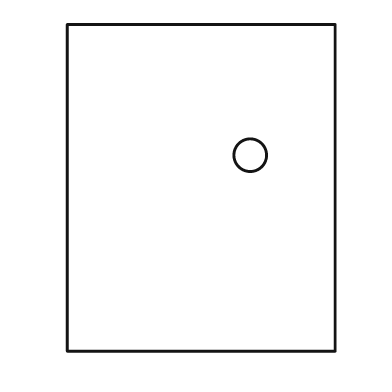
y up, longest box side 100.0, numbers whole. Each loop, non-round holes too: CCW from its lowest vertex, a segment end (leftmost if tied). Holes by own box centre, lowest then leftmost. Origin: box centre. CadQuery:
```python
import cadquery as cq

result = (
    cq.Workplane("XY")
    .moveTo(-41.0, -50.0)
    .lineTo(41.0, -50.0)
    .lineTo(41.0, 50.0)
    .lineTo(-41.0, 50.0)
    .close()
    .moveTo(15.0, 10.0)
    .circle(5.0)
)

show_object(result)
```